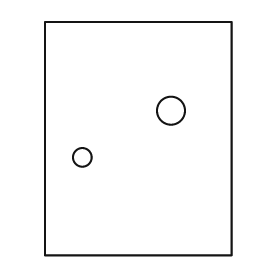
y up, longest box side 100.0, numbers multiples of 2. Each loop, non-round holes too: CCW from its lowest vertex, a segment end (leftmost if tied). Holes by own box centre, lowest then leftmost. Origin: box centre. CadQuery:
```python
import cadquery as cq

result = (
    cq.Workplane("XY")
    .moveTo(-40.0, -50.0)
    .lineTo(40.0, -50.0)
    .lineTo(40.0, 50.0)
    .lineTo(-40.0, 50.0)
    .close()
    .moveTo(-24.0, -8.0)
    .circle(4.0)
    .moveTo(14.0, 12.0)
    .circle(6.0)
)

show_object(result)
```